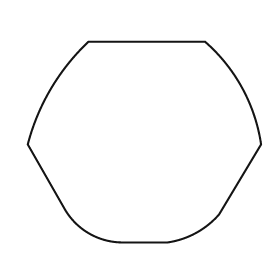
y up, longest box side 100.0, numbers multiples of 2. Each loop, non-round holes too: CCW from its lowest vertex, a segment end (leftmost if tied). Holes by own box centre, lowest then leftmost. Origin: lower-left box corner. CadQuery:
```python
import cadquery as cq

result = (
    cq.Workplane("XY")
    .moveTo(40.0, 0.0)
    .lineTo(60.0, 0.0)
    .threePointArc((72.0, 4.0), (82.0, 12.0))
    .lineTo(100.0, 42.0)
    .threePointArc((92.0, 66.0), (76.0, 86.0))
    .lineTo(26.0, 86.0)
    .threePointArc((10.0, 66.0), (0.0, 42.0))
    .lineTo(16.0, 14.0)
    .threePointArc((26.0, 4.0), (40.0, 0.0))
    .close()
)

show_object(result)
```